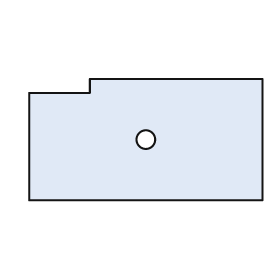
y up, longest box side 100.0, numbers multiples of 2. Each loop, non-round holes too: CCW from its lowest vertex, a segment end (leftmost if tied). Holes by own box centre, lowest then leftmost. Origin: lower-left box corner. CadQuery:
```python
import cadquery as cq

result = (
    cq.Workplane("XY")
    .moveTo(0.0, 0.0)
    .lineTo(100.0, 0.0)
    .lineTo(100.0, 52.0)
    .lineTo(26.0, 52.0)
    .lineTo(26.0, 46.0)
    .lineTo(0.0, 46.0)
    .close()
    .moveTo(50.0, 26.0)
    .circle(4.0)
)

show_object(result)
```